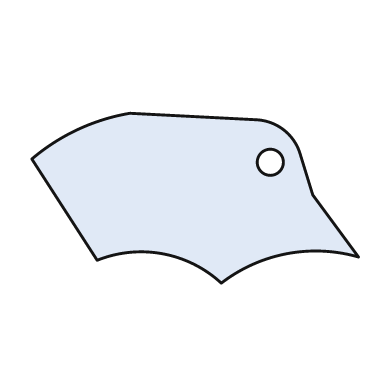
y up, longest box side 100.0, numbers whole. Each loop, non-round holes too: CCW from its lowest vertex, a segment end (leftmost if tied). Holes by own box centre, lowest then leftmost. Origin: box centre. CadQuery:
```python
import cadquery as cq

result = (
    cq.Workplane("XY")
    .moveTo(8.0, -26.0)
    .threePointArc((28.0, -17.0), (50.0, -18.0))
    .lineTo(36.0, 1.0)
    .lineTo(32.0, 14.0)
    .threePointArc((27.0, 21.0), (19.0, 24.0))
    .lineTo(-20.0, 26.0)
    .threePointArc((-36.0, 21.0), (-50.0, 12.0))
    .lineTo(-30.0, -19.0)
    .threePointArc((-10.0, -17.0), (8.0, -26.0))
    .close()
    .moveTo(23.0, 11.0)
    .circle(4.0)
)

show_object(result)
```